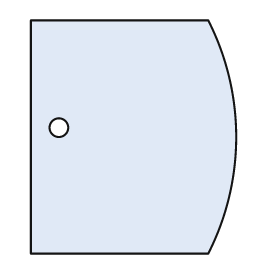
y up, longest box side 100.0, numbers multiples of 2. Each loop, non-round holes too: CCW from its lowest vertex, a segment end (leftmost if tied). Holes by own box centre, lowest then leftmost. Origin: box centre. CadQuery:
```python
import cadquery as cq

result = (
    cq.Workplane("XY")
    .moveTo(-44.0, -50.0)
    .lineTo(32.0, -50.0)
    .threePointArc((44.0, 0.0), (32.0, 50.0))
    .lineTo(-44.0, 50.0)
    .close()
    .moveTo(-32.0, 4.0)
    .circle(4.0)
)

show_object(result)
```